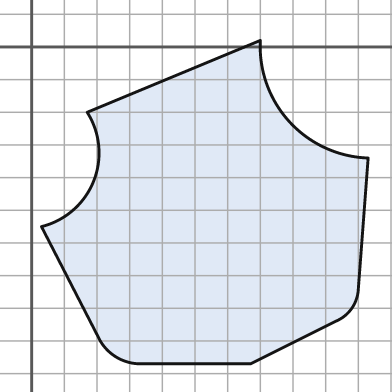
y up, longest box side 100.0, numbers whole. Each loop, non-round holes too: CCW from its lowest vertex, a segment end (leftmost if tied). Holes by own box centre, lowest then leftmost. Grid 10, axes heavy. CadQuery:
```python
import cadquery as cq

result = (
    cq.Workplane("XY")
    .moveTo(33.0, -97.0)
    .lineTo(67.0, -97.0)
    .lineTo(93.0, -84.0)
    .threePointArc((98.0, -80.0), (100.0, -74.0))
    .lineTo(103.0, -34.0)
    .threePointArc((79.0, -23.0), (70.0, 2.0))
    .lineTo(17.0, -20.0)
    .threePointArc((19.0, -41.0), (3.0, -55.0))
    .lineTo(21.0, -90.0)
    .threePointArc((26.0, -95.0), (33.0, -97.0))
    .close()
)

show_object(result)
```